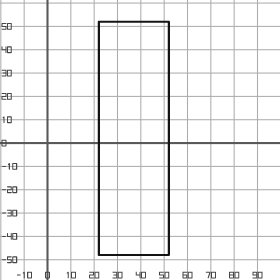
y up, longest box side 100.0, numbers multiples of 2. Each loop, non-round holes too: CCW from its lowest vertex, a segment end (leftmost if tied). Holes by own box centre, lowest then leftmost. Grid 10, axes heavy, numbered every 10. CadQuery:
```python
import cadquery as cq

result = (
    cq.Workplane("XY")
    .moveTo(22.0, -48.0)
    .lineTo(52.0, -48.0)
    .lineTo(52.0, 52.0)
    .lineTo(22.0, 52.0)
    .close()
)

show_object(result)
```